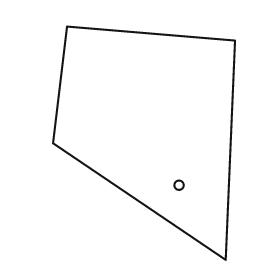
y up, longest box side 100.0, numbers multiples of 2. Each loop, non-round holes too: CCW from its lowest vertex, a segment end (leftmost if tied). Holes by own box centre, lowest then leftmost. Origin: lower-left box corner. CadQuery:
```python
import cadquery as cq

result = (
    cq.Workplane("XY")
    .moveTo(74.0, 0.0)
    .lineTo(78.0, 94.0)
    .lineTo(6.0, 100.0)
    .lineTo(0.0, 50.0)
    .close()
    .moveTo(54.0, 32.0)
    .circle(2.0)
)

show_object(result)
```